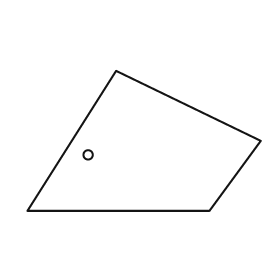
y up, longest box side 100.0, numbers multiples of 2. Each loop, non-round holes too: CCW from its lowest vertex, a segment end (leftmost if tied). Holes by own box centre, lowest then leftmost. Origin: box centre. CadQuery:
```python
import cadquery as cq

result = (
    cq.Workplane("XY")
    .moveTo(-50.0, -30.0)
    .lineTo(28.0, -30.0)
    .lineTo(50.0, 0.0)
    .lineTo(-12.0, 30.0)
    .close()
    .moveTo(-24.0, -6.0)
    .circle(2.0)
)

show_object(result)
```